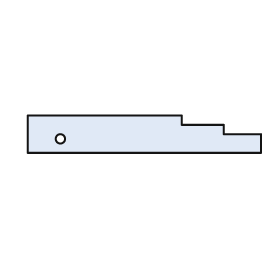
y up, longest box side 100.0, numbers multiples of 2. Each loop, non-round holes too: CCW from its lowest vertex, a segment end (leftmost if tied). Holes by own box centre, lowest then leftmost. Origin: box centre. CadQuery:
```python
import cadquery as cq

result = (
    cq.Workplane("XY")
    .moveTo(-50.0, -8.0)
    .lineTo(50.0, -8.0)
    .lineTo(50.0, 0.0)
    .lineTo(34.0, 0.0)
    .lineTo(34.0, 4.0)
    .lineTo(16.0, 4.0)
    .lineTo(16.0, 8.0)
    .lineTo(-50.0, 8.0)
    .close()
    .moveTo(-36.0, -2.0)
    .circle(2.0)
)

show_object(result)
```